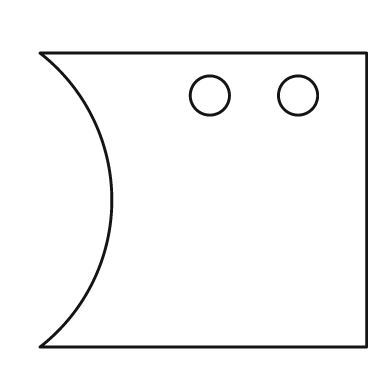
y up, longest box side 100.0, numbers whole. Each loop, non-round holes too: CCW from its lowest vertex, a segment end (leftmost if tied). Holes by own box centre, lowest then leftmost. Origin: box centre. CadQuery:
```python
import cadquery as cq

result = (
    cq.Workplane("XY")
    .moveTo(-50.0, -45.0)
    .lineTo(50.0, -45.0)
    .lineTo(50.0, 45.0)
    .lineTo(-50.0, 45.0)
    .threePointArc((-28.0, 0.0), (-50.0, -45.0))
    .close()
    .moveTo(2.0, 32.0)
    .circle(6.0)
    .moveTo(29.0, 32.0)
    .circle(6.0)
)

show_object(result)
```